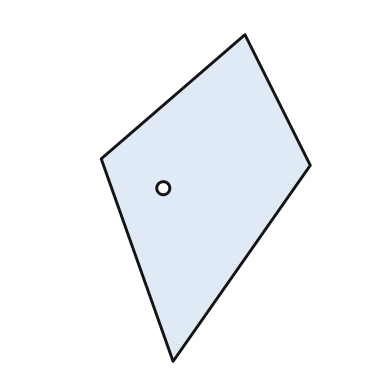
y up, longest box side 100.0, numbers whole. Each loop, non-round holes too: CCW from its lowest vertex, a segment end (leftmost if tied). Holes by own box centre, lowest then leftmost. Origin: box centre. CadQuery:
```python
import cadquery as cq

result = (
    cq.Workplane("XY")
    .moveTo(-10.0, -50.0)
    .lineTo(32.0, 10.0)
    .lineTo(12.0, 50.0)
    .lineTo(-32.0, 12.0)
    .close()
    .moveTo(-13.0, 3.0)
    .circle(2.0)
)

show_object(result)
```